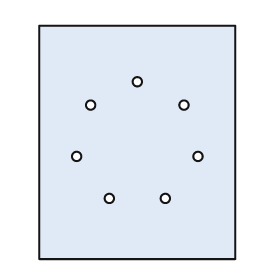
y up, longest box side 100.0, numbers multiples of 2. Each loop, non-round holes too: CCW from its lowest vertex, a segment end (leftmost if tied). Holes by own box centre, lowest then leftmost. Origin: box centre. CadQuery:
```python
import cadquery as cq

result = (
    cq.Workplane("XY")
    .moveTo(-42.0, -50.0)
    .lineTo(42.0, -50.0)
    .lineTo(42.0, 50.0)
    .lineTo(-42.0, 50.0)
    .close()
    .moveTo(-12.0, -24.0)
    .circle(2.0)
    .moveTo(12.0, -24.0)
    .circle(2.0)
    .moveTo(-26.0, -6.0)
    .circle(2.0)
    .moveTo(26.0, -6.0)
    .circle(2.0)
    .moveTo(-20.0, 16.0)
    .circle(2.0)
    .moveTo(20.0, 16.0)
    .circle(2.0)
    .moveTo(0.0, 26.0)
    .circle(2.0)
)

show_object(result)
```